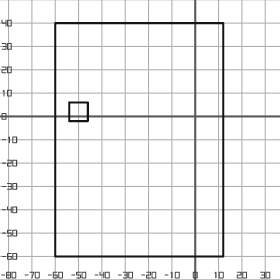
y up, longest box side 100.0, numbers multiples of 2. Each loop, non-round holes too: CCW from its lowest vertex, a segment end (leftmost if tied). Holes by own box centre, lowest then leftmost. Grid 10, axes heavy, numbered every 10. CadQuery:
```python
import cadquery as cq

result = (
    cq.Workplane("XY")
    .moveTo(-60.0, -60.0)
    .lineTo(12.0, -60.0)
    .lineTo(12.0, 40.0)
    .lineTo(-60.0, 40.0)
    .close()
    .moveTo(-54.0, -2.0)
    .lineTo(-46.0, -2.0)
    .lineTo(-46.0, 6.0)
    .lineTo(-54.0, 6.0)
    .close()
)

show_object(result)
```